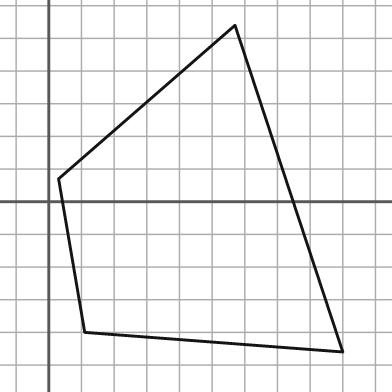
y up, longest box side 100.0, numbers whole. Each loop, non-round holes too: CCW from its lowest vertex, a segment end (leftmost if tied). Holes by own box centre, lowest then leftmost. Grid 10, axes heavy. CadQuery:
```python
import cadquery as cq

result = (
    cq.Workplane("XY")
    .moveTo(90.0, -46.0)
    .lineTo(57.0, 54.0)
    .lineTo(3.0, 7.0)
    .lineTo(11.0, -40.0)
    .close()
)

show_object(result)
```